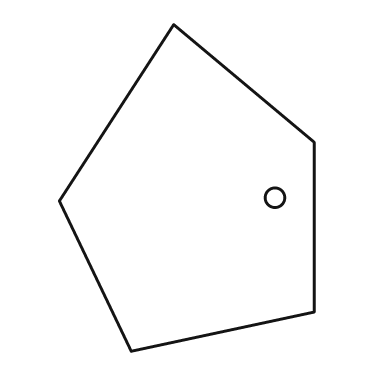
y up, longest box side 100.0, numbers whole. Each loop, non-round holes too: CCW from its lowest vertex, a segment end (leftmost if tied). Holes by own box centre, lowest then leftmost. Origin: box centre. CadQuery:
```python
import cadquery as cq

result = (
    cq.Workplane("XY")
    .moveTo(-17.0, -50.0)
    .lineTo(39.0, -38.0)
    .lineTo(39.0, 14.0)
    .lineTo(-4.0, 50.0)
    .lineTo(-39.0, -4.0)
    .close()
    .moveTo(27.0, -3.0)
    .circle(3.0)
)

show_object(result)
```